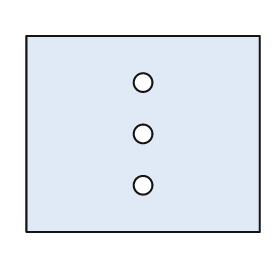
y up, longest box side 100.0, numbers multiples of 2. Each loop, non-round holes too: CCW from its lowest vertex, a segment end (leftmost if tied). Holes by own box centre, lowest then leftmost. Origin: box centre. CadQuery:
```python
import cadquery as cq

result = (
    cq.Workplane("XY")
    .moveTo(-50.0, -42.0)
    .lineTo(50.0, -42.0)
    .lineTo(50.0, 42.0)
    .lineTo(-50.0, 42.0)
    .close()
    .moveTo(0.0, -22.0)
    .circle(4.0)
    .moveTo(0.0, 0.0)
    .circle(4.0)
    .moveTo(0.0, 22.0)
    .circle(4.0)
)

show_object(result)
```